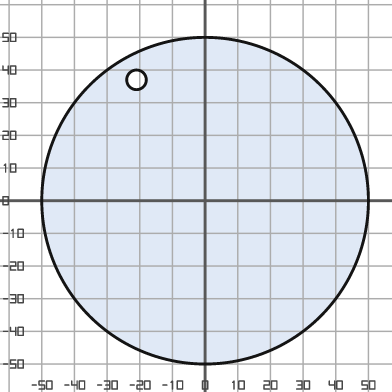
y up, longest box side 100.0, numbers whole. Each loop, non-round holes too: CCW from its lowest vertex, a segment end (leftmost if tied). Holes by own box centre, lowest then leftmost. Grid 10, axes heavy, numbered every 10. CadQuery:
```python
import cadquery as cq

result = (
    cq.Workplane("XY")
    .moveTo(0.0, 0.0)
    .circle(50.0)
    .moveTo(-21.0, 37.0)
    .circle(3.0)
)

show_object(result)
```